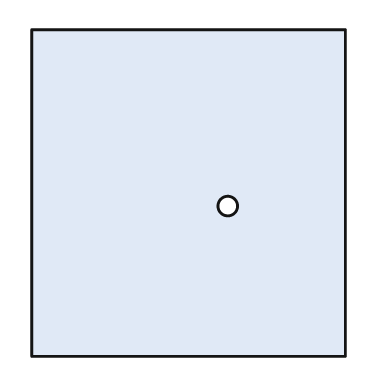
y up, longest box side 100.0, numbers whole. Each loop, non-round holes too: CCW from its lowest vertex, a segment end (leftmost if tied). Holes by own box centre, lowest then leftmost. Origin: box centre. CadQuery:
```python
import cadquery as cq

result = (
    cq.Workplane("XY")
    .moveTo(-48.0, -50.0)
    .lineTo(48.0, -50.0)
    .lineTo(48.0, 50.0)
    .lineTo(-48.0, 50.0)
    .close()
    .moveTo(12.0, -4.0)
    .circle(3.0)
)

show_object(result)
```